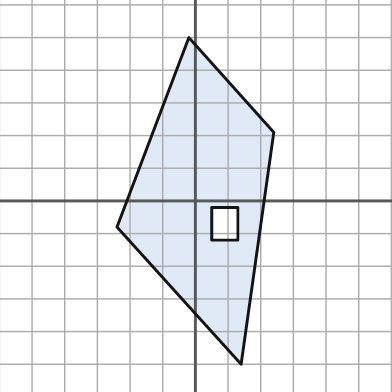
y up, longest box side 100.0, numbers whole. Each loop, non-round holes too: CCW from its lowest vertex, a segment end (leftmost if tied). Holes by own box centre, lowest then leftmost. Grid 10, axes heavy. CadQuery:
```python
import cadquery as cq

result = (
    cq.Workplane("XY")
    .moveTo(14.0, -50.0)
    .lineTo(24.0, 21.0)
    .lineTo(-2.0, 50.0)
    .lineTo(-24.0, -8.0)
    .close()
    .moveTo(5.0, -12.0)
    .lineTo(13.0, -12.0)
    .lineTo(13.0, -2.0)
    .lineTo(5.0, -2.0)
    .close()
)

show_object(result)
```